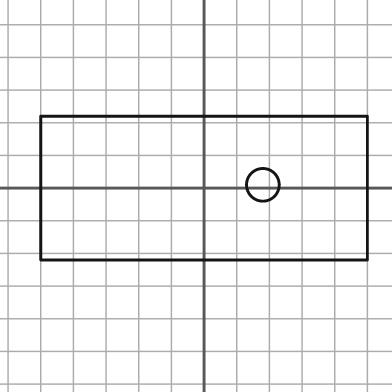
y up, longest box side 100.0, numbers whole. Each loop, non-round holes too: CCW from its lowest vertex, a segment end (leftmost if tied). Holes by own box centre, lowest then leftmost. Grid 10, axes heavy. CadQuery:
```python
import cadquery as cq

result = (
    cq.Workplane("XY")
    .moveTo(-50.0, -22.0)
    .lineTo(50.0, -22.0)
    .lineTo(50.0, 22.0)
    .lineTo(-50.0, 22.0)
    .close()
    .moveTo(18.0, 1.0)
    .circle(5.0)
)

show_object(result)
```